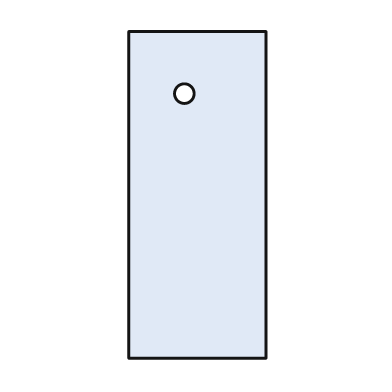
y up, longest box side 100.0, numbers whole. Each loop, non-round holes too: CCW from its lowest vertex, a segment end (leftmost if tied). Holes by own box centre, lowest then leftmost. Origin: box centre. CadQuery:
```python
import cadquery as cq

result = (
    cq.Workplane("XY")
    .moveTo(-21.0, -50.0)
    .lineTo(21.0, -50.0)
    .lineTo(21.0, 50.0)
    .lineTo(-21.0, 50.0)
    .close()
    .moveTo(-4.0, 31.0)
    .circle(3.0)
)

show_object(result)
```